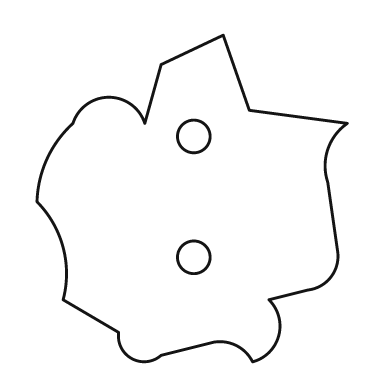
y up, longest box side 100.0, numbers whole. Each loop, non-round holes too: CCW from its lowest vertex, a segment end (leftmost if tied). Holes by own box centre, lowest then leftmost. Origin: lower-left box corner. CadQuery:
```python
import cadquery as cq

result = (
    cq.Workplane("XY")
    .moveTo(66.0, 0.0)
    .threePointArc((74.0, 8.0), (71.0, 19.0))
    .lineTo(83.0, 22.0)
    .threePointArc((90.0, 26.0), (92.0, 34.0))
    .lineTo(89.0, 55.0)
    .threePointArc((89.0, 65.0), (95.0, 73.0))
    .lineTo(65.0, 77.0)
    .lineTo(57.0, 100.0)
    .lineTo(38.0, 91.0)
    .lineTo(33.0, 73.0)
    .threePointArc((22.0, 81.0), (11.0, 73.0))
    .threePointArc((3.0, 62.0), (0.0, 49.0))
    .threePointArc((8.0, 35.0), (8.0, 19.0))
    .lineTo(25.0, 9.0)
    .threePointArc((29.0, 1.0), (38.0, 2.0))
    .lineTo(54.0, 6.0)
    .threePointArc((61.0, 5.0), (66.0, 0.0))
    .close()
    .moveTo(48.0, 32.0)
    .circle(5.0)
    .moveTo(48.0, 69.0)
    .circle(5.0)
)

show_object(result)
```